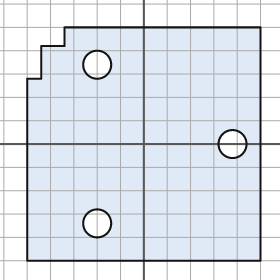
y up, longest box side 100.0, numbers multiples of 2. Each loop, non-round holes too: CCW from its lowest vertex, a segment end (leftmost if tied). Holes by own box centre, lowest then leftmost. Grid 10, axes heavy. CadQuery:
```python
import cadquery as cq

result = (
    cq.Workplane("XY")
    .moveTo(-50.0, -50.0)
    .lineTo(50.0, -50.0)
    .lineTo(50.0, 50.0)
    .lineTo(-34.0, 50.0)
    .lineTo(-34.0, 42.0)
    .lineTo(-44.0, 42.0)
    .lineTo(-44.0, 28.0)
    .lineTo(-50.0, 28.0)
    .close()
    .moveTo(-20.0, -34.0)
    .circle(6.0)
    .moveTo(38.0, 0.0)
    .circle(6.0)
    .moveTo(-20.0, 34.0)
    .circle(6.0)
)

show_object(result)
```